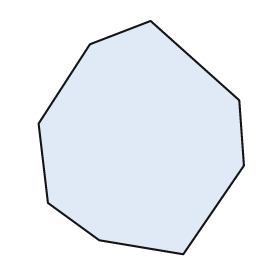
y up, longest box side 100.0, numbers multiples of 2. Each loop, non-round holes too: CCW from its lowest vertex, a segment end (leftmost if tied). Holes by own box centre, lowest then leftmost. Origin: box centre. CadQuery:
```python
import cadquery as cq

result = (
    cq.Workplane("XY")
    .moveTo(18.0, -50.0)
    .lineTo(44.0, -12.0)
    .lineTo(42.0, 16.0)
    .lineTo(4.0, 50.0)
    .lineTo(-22.0, 40.0)
    .lineTo(-44.0, 6.0)
    .lineTo(-40.0, -28.0)
    .lineTo(-18.0, -44.0)
    .close()
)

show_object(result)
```